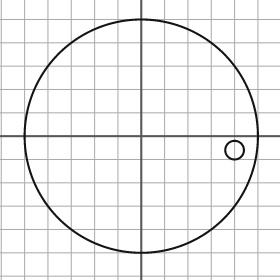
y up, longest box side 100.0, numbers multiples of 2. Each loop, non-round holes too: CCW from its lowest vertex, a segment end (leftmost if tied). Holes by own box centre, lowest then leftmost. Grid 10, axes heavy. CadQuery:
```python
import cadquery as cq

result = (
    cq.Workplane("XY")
    .moveTo(0.0, 0.0)
    .circle(50.0)
    .moveTo(40.0, -6.0)
    .circle(4.0)
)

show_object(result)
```